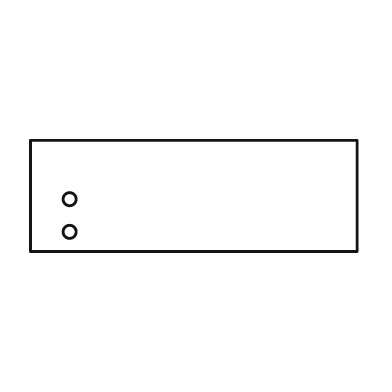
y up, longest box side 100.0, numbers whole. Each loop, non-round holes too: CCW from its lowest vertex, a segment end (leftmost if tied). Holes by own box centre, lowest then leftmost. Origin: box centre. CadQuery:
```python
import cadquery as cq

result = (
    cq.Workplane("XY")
    .moveTo(-50.0, -17.0)
    .lineTo(50.0, -17.0)
    .lineTo(50.0, 17.0)
    .lineTo(-50.0, 17.0)
    .close()
    .moveTo(-38.0, -11.0)
    .circle(2.0)
    .moveTo(-38.0, -1.0)
    .circle(2.0)
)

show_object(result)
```